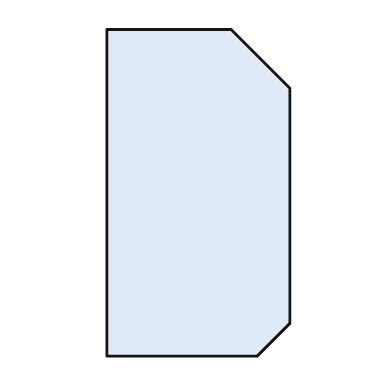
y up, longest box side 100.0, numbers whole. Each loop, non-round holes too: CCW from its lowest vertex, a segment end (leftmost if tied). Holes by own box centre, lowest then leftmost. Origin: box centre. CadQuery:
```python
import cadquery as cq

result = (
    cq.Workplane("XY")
    .moveTo(-28.0, -50.0)
    .lineTo(18.0, -50.0)
    .lineTo(28.0, -40.0)
    .lineTo(28.0, 32.0)
    .lineTo(10.0, 50.0)
    .lineTo(-28.0, 50.0)
    .close()
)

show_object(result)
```